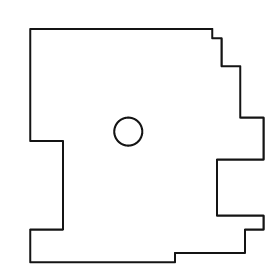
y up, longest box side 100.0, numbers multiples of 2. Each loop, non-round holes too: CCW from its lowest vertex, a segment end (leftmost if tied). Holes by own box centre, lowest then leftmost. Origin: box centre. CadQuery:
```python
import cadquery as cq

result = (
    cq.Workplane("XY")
    .moveTo(-50.0, -50.0)
    .lineTo(12.0, -50.0)
    .lineTo(12.0, -46.0)
    .lineTo(42.0, -46.0)
    .lineTo(42.0, -36.0)
    .lineTo(50.0, -36.0)
    .lineTo(50.0, -30.0)
    .lineTo(30.0, -30.0)
    .lineTo(30.0, -6.0)
    .lineTo(50.0, -6.0)
    .lineTo(50.0, 12.0)
    .lineTo(40.0, 12.0)
    .lineTo(40.0, 34.0)
    .lineTo(32.0, 34.0)
    .lineTo(32.0, 46.0)
    .lineTo(28.0, 46.0)
    .lineTo(28.0, 50.0)
    .lineTo(-50.0, 50.0)
    .lineTo(-50.0, 2.0)
    .lineTo(-36.0, 2.0)
    .lineTo(-36.0, -36.0)
    .lineTo(-50.0, -36.0)
    .close()
    .moveTo(-8.0, 6.0)
    .circle(6.0)
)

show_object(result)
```